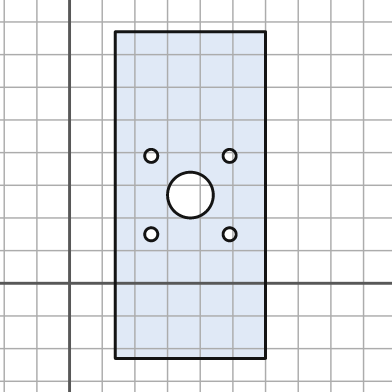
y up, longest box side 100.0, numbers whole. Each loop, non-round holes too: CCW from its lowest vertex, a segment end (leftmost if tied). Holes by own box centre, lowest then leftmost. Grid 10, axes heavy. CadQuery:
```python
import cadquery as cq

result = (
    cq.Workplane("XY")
    .moveTo(14.0, -23.0)
    .lineTo(60.0, -23.0)
    .lineTo(60.0, 77.0)
    .lineTo(14.0, 77.0)
    .close()
    .moveTo(25.0, 15.0)
    .circle(2.0)
    .moveTo(49.0, 15.0)
    .circle(2.0)
    .moveTo(37.0, 27.0)
    .circle(7.0)
    .moveTo(25.0, 39.0)
    .circle(2.0)
    .moveTo(49.0, 39.0)
    .circle(2.0)
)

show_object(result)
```